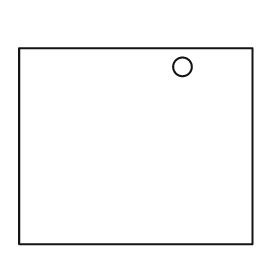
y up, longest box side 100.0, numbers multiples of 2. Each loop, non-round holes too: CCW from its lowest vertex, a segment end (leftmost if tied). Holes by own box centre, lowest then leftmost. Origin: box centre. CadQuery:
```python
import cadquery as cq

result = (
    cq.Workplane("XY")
    .moveTo(-50.0, -42.0)
    .lineTo(50.0, -42.0)
    .lineTo(50.0, 42.0)
    .lineTo(-50.0, 42.0)
    .close()
    .moveTo(20.0, 34.0)
    .circle(4.0)
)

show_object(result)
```